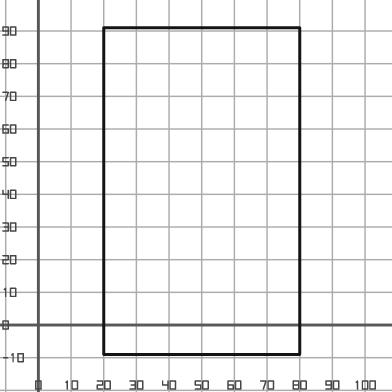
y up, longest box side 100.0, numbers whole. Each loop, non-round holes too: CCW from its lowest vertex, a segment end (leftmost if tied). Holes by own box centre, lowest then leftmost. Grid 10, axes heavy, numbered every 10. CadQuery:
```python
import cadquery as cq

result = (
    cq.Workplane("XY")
    .moveTo(20.0, -9.0)
    .lineTo(80.0, -9.0)
    .lineTo(80.0, 91.0)
    .lineTo(20.0, 91.0)
    .close()
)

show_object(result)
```